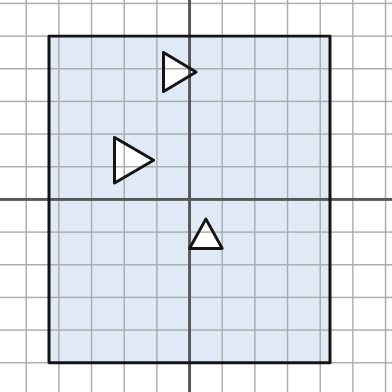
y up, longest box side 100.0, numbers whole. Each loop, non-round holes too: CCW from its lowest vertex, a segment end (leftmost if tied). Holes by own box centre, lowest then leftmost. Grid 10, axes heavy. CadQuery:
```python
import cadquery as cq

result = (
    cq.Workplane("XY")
    .moveTo(-43.0, -50.0)
    .lineTo(43.0, -50.0)
    .lineTo(43.0, 50.0)
    .lineTo(-43.0, 50.0)
    .close()
    .moveTo(0.0, -15.0)
    .lineTo(10.0, -15.0)
    .lineTo(5.0, -6.0)
    .close()
    .moveTo(-23.0, 5.0)
    .lineTo(-11.0, 12.0)
    .lineTo(-23.0, 19.0)
    .close()
    .moveTo(-8.0, 33.0)
    .lineTo(2.0, 39.0)
    .lineTo(-8.0, 45.0)
    .close()
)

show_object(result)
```